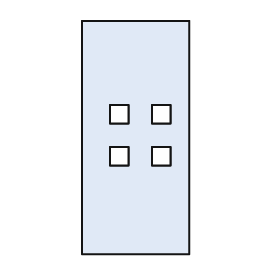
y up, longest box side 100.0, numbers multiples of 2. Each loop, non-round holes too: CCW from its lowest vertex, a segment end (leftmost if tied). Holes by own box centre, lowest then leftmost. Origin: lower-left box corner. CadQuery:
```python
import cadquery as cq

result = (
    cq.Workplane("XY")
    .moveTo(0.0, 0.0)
    .lineTo(46.0, 0.0)
    .lineTo(46.0, 100.0)
    .lineTo(0.0, 100.0)
    .close()
    .moveTo(12.0, 38.0)
    .lineTo(20.0, 38.0)
    .lineTo(20.0, 46.0)
    .lineTo(12.0, 46.0)
    .close()
    .moveTo(30.0, 38.0)
    .lineTo(38.0, 38.0)
    .lineTo(38.0, 46.0)
    .lineTo(30.0, 46.0)
    .close()
    .moveTo(12.0, 56.0)
    .lineTo(20.0, 56.0)
    .lineTo(20.0, 64.0)
    .lineTo(12.0, 64.0)
    .close()
    .moveTo(30.0, 56.0)
    .lineTo(38.0, 56.0)
    .lineTo(38.0, 64.0)
    .lineTo(30.0, 64.0)
    .close()
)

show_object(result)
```